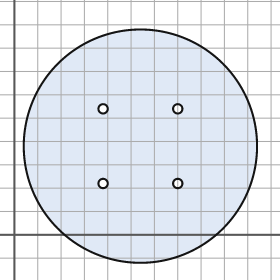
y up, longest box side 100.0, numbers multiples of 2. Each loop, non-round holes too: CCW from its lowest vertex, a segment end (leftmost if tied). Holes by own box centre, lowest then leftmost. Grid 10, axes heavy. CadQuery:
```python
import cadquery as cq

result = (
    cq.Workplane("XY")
    .moveTo(54.0, 38.0)
    .circle(50.0)
    .moveTo(38.0, 22.0)
    .circle(2.0)
    .moveTo(70.0, 22.0)
    .circle(2.0)
    .moveTo(38.0, 54.0)
    .circle(2.0)
    .moveTo(70.0, 54.0)
    .circle(2.0)
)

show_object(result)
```